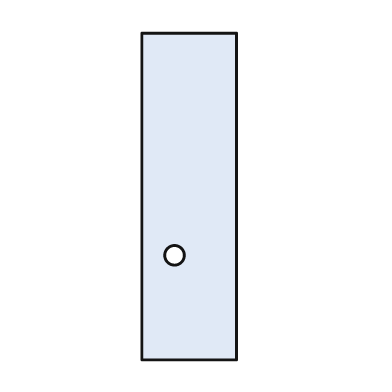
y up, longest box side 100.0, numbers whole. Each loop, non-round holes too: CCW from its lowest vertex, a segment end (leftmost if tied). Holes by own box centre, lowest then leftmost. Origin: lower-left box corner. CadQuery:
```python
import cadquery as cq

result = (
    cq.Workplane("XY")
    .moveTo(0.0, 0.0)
    .lineTo(29.0, 0.0)
    .lineTo(29.0, 100.0)
    .lineTo(0.0, 100.0)
    .close()
    .moveTo(10.0, 32.0)
    .circle(3.0)
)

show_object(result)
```